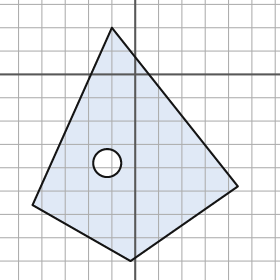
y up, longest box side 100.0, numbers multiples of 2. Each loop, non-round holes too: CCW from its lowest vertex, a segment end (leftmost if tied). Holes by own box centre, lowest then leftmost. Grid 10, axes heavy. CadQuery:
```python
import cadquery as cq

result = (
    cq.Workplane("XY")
    .moveTo(-2.0, -80.0)
    .lineTo(44.0, -48.0)
    .lineTo(-10.0, 20.0)
    .lineTo(-44.0, -56.0)
    .close()
    .moveTo(-12.0, -38.0)
    .circle(6.0)
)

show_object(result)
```